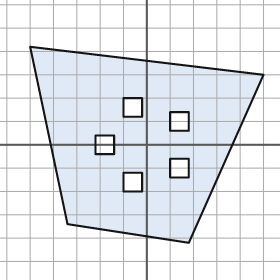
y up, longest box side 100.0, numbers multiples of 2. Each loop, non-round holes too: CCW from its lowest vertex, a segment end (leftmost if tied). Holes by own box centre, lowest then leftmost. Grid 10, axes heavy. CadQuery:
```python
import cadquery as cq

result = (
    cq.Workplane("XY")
    .moveTo(18.0, -42.0)
    .lineTo(50.0, 30.0)
    .lineTo(-50.0, 42.0)
    .lineTo(-34.0, -34.0)
    .close()
    .moveTo(-10.0, -20.0)
    .lineTo(-2.0, -20.0)
    .lineTo(-2.0, -12.0)
    .lineTo(-10.0, -12.0)
    .close()
    .moveTo(10.0, -14.0)
    .lineTo(18.0, -14.0)
    .lineTo(18.0, -6.0)
    .lineTo(10.0, -6.0)
    .close()
    .moveTo(-22.0, -4.0)
    .lineTo(-14.0, -4.0)
    .lineTo(-14.0, 4.0)
    .lineTo(-22.0, 4.0)
    .close()
    .moveTo(10.0, 6.0)
    .lineTo(18.0, 6.0)
    .lineTo(18.0, 14.0)
    .lineTo(10.0, 14.0)
    .close()
    .moveTo(-10.0, 12.0)
    .lineTo(-2.0, 12.0)
    .lineTo(-2.0, 20.0)
    .lineTo(-10.0, 20.0)
    .close()
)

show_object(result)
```